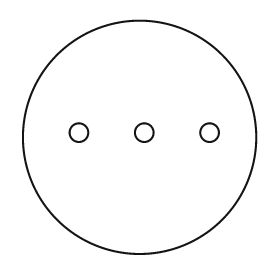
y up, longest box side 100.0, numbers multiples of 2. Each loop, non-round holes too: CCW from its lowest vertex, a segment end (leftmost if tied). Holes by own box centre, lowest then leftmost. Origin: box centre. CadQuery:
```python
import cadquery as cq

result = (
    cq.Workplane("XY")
    .moveTo(0.0, 0.0)
    .circle(50.0)
    .moveTo(-26.0, 2.0)
    .circle(4.0)
    .moveTo(2.0, 2.0)
    .circle(4.0)
    .moveTo(30.0, 2.0)
    .circle(4.0)
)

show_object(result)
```